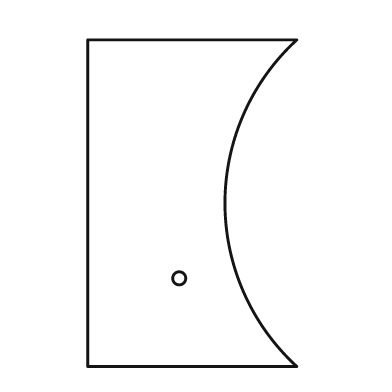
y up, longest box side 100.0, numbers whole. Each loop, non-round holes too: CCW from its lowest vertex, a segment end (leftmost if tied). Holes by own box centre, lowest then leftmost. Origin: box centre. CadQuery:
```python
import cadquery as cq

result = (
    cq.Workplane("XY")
    .moveTo(-32.0, -50.0)
    .lineTo(32.0, -50.0)
    .threePointArc((10.0, 0.0), (32.0, 50.0))
    .lineTo(-32.0, 50.0)
    .close()
    .moveTo(-4.0, -23.0)
    .circle(2.0)
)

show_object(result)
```